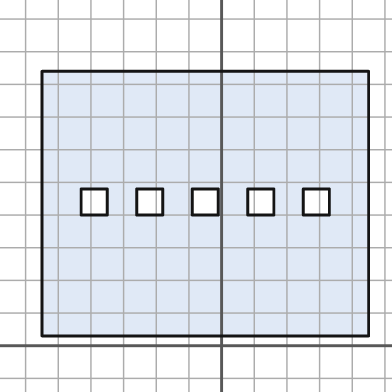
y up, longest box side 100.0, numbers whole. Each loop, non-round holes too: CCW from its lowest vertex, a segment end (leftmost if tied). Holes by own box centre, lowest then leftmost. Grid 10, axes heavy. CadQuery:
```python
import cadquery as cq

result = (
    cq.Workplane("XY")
    .moveTo(-55.0, 3.0)
    .lineTo(45.0, 3.0)
    .lineTo(45.0, 84.0)
    .lineTo(-55.0, 84.0)
    .close()
    .moveTo(-43.0, 40.0)
    .lineTo(-35.0, 40.0)
    .lineTo(-35.0, 48.0)
    .lineTo(-43.0, 48.0)
    .close()
    .moveTo(-26.0, 40.0)
    .lineTo(-18.0, 40.0)
    .lineTo(-18.0, 48.0)
    .lineTo(-26.0, 48.0)
    .close()
    .moveTo(-9.0, 40.0)
    .lineTo(-1.0, 40.0)
    .lineTo(-1.0, 48.0)
    .lineTo(-9.0, 48.0)
    .close()
    .moveTo(8.0, 40.0)
    .lineTo(16.0, 40.0)
    .lineTo(16.0, 48.0)
    .lineTo(8.0, 48.0)
    .close()
    .moveTo(25.0, 40.0)
    .lineTo(33.0, 40.0)
    .lineTo(33.0, 48.0)
    .lineTo(25.0, 48.0)
    .close()
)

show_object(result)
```